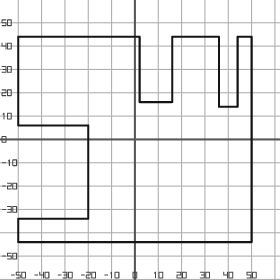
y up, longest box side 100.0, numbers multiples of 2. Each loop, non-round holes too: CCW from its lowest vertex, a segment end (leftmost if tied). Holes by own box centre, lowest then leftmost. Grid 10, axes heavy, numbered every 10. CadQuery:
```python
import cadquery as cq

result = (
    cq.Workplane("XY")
    .moveTo(-50.0, -44.0)
    .lineTo(50.0, -44.0)
    .lineTo(50.0, 44.0)
    .lineTo(44.0, 44.0)
    .lineTo(44.0, 14.0)
    .lineTo(36.0, 14.0)
    .lineTo(36.0, 44.0)
    .lineTo(16.0, 44.0)
    .lineTo(16.0, 16.0)
    .lineTo(2.0, 16.0)
    .lineTo(2.0, 44.0)
    .lineTo(-50.0, 44.0)
    .lineTo(-50.0, 6.0)
    .lineTo(-20.0, 6.0)
    .lineTo(-20.0, -34.0)
    .lineTo(-50.0, -34.0)
    .close()
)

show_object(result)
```